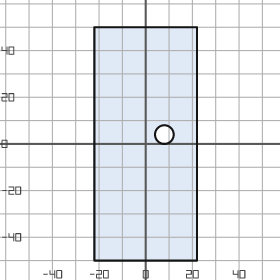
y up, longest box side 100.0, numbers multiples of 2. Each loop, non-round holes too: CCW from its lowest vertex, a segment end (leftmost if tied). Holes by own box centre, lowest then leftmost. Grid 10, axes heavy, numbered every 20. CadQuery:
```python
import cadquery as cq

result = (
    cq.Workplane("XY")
    .moveTo(-22.0, -50.0)
    .lineTo(22.0, -50.0)
    .lineTo(22.0, 50.0)
    .lineTo(-22.0, 50.0)
    .close()
    .moveTo(8.0, 4.0)
    .circle(4.0)
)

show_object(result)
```